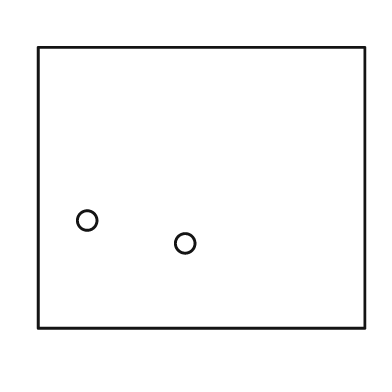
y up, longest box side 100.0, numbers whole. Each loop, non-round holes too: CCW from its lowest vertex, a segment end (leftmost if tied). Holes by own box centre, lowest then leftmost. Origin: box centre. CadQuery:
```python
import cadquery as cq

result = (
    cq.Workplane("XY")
    .moveTo(-50.0, -43.0)
    .lineTo(50.0, -43.0)
    .lineTo(50.0, 43.0)
    .lineTo(-50.0, 43.0)
    .close()
    .moveTo(-5.0, -17.0)
    .circle(3.0)
    .moveTo(-35.0, -10.0)
    .circle(3.0)
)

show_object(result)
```